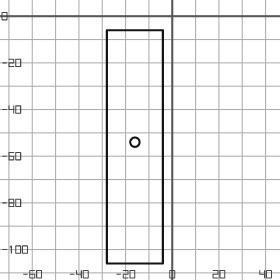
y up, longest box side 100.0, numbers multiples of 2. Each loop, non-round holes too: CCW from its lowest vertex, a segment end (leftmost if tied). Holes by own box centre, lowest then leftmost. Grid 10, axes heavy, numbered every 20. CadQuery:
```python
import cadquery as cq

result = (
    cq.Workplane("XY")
    .moveTo(-28.0, -106.0)
    .lineTo(-4.0, -106.0)
    .lineTo(-4.0, -6.0)
    .lineTo(-28.0, -6.0)
    .close()
    .moveTo(-16.0, -54.0)
    .circle(2.0)
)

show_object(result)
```